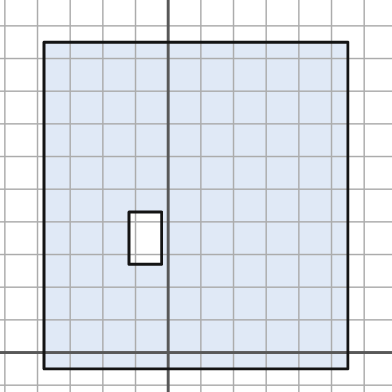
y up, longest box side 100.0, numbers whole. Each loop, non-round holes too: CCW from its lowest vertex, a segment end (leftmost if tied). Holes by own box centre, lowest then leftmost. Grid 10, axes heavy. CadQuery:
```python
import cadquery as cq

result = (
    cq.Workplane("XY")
    .moveTo(-38.0, -5.0)
    .lineTo(55.0, -5.0)
    .lineTo(55.0, 95.0)
    .lineTo(-38.0, 95.0)
    .close()
    .moveTo(-12.0, 27.0)
    .lineTo(-2.0, 27.0)
    .lineTo(-2.0, 43.0)
    .lineTo(-12.0, 43.0)
    .close()
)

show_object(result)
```